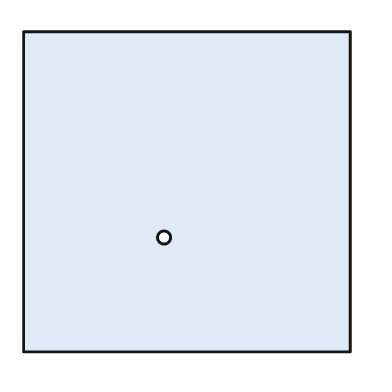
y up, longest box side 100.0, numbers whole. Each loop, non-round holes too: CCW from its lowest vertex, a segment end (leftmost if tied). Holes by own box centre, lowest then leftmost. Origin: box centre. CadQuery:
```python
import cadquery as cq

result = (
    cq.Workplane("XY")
    .moveTo(-50.0, -49.0)
    .lineTo(50.0, -49.0)
    .lineTo(50.0, 49.0)
    .lineTo(-50.0, 49.0)
    .close()
    .moveTo(-7.0, -14.0)
    .circle(2.0)
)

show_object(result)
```